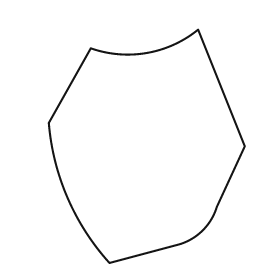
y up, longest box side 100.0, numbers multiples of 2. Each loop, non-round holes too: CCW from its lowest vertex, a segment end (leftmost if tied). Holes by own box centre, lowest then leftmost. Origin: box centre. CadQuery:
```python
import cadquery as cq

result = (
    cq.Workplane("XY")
    .moveTo(-16.0, -50.0)
    .lineTo(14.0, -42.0)
    .threePointArc((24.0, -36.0), (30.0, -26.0))
    .lineTo(42.0, 0.0)
    .lineTo(22.0, 50.0)
    .threePointArc((0.0, 40.0), (-24.0, 42.0))
    .lineTo(-42.0, 10.0)
    .threePointArc((-34.0, -22.0), (-16.0, -50.0))
    .close()
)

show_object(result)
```